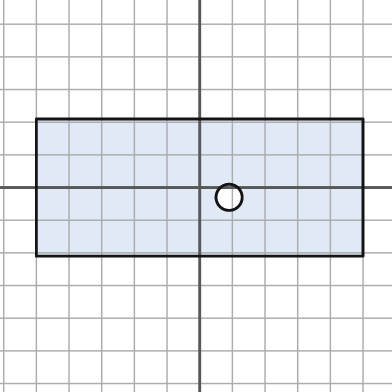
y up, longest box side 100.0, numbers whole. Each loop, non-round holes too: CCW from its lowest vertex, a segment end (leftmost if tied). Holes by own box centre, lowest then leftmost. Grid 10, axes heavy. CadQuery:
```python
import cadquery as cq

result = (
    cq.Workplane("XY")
    .moveTo(-50.0, -21.0)
    .lineTo(50.0, -21.0)
    .lineTo(50.0, 21.0)
    .lineTo(-50.0, 21.0)
    .close()
    .moveTo(9.0, -3.0)
    .circle(4.0)
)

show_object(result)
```